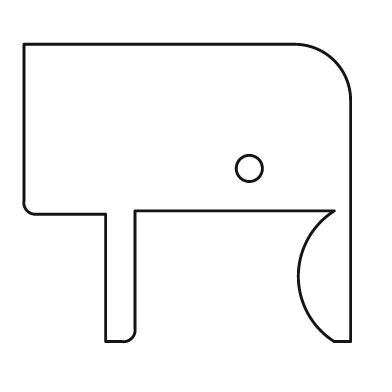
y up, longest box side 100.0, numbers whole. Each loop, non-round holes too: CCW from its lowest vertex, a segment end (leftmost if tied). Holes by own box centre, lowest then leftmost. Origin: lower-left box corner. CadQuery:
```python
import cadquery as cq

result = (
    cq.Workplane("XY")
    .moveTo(25.0, 0.0)
    .lineTo(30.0, 0.0)
    .threePointArc((33.0, 1.0), (34.0, 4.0))
    .lineTo(34.0, 40.0)
    .lineTo(95.0, 40.0)
    .threePointArc((84.0, 20.0), (95.0, 0.0))
    .lineTo(100.0, 0.0)
    .lineTo(100.0, 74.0)
    .threePointArc((95.0, 86.0), (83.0, 91.0))
    .lineTo(0.0, 91.0)
    .lineTo(0.0, 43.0)
    .threePointArc((1.0, 40.0), (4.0, 39.0))
    .lineTo(25.0, 39.0)
    .close()
    .moveTo(69.0, 53.0)
    .circle(4.0)
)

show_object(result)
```